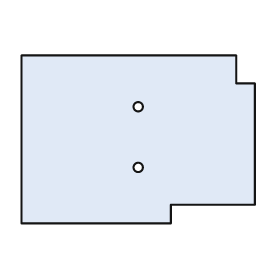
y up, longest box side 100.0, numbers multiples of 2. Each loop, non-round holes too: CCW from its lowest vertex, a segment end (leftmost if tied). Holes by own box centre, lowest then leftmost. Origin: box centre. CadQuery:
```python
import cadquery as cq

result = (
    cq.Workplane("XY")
    .moveTo(-50.0, -36.0)
    .lineTo(14.0, -36.0)
    .lineTo(14.0, -28.0)
    .lineTo(50.0, -28.0)
    .lineTo(50.0, 24.0)
    .lineTo(42.0, 24.0)
    .lineTo(42.0, 36.0)
    .lineTo(-50.0, 36.0)
    .close()
    .moveTo(0.0, -12.0)
    .circle(2.0)
    .moveTo(0.0, 14.0)
    .circle(2.0)
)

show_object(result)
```